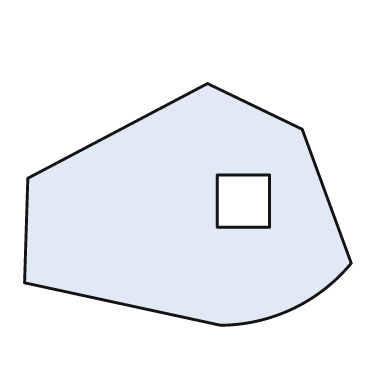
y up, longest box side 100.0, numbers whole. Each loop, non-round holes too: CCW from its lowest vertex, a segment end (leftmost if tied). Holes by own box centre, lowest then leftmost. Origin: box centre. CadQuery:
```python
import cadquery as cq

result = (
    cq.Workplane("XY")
    .moveTo(10.0, -37.0)
    .threePointArc((32.0, -32.0), (50.0, -18.0))
    .lineTo(35.0, 23.0)
    .lineTo(6.0, 37.0)
    .lineTo(-49.0, 8.0)
    .lineTo(-50.0, -24.0)
    .close()
    .moveTo(9.0, -7.0)
    .lineTo(25.0, -7.0)
    .lineTo(25.0, 9.0)
    .lineTo(9.0, 9.0)
    .close()
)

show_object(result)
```